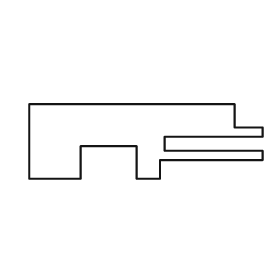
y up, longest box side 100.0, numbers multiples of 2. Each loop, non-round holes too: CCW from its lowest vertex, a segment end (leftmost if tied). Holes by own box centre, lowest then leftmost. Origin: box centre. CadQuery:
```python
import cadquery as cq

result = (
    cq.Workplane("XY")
    .moveTo(-50.0, -16.0)
    .lineTo(-28.0, -16.0)
    .lineTo(-28.0, -2.0)
    .lineTo(-4.0, -2.0)
    .lineTo(-4.0, -16.0)
    .lineTo(6.0, -16.0)
    .lineTo(6.0, -8.0)
    .lineTo(50.0, -8.0)
    .lineTo(50.0, -4.0)
    .lineTo(8.0, -4.0)
    .lineTo(8.0, 2.0)
    .lineTo(50.0, 2.0)
    .lineTo(50.0, 6.0)
    .lineTo(38.0, 6.0)
    .lineTo(38.0, 16.0)
    .lineTo(-50.0, 16.0)
    .close()
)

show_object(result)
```